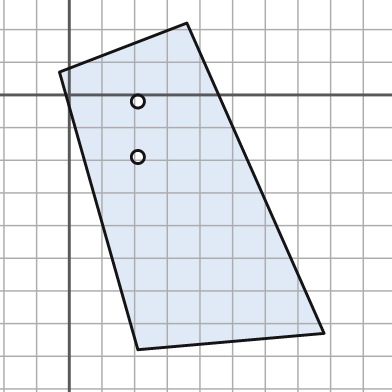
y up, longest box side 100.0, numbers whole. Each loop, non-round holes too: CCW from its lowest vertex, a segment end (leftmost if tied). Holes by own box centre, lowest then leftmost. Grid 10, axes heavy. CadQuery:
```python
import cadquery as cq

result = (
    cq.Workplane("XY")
    .moveTo(21.0, -78.0)
    .lineTo(78.0, -73.0)
    .lineTo(36.0, 22.0)
    .lineTo(-3.0, 7.0)
    .close()
    .moveTo(21.0, -19.0)
    .circle(2.0)
    .moveTo(21.0, -2.0)
    .circle(2.0)
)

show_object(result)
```